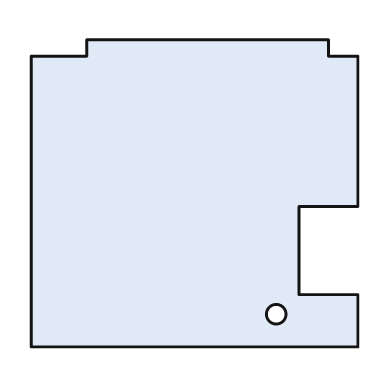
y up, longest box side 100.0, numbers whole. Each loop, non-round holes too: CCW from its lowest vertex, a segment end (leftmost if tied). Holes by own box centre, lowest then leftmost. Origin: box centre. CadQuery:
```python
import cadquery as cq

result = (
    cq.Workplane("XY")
    .moveTo(-50.0, -47.0)
    .lineTo(50.0, -47.0)
    .lineTo(50.0, -31.0)
    .lineTo(32.0, -31.0)
    .lineTo(32.0, -4.0)
    .lineTo(50.0, -4.0)
    .lineTo(50.0, 42.0)
    .lineTo(41.0, 42.0)
    .lineTo(41.0, 47.0)
    .lineTo(-33.0, 47.0)
    .lineTo(-33.0, 42.0)
    .lineTo(-50.0, 42.0)
    .close()
    .moveTo(25.0, -37.0)
    .circle(3.0)
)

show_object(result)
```